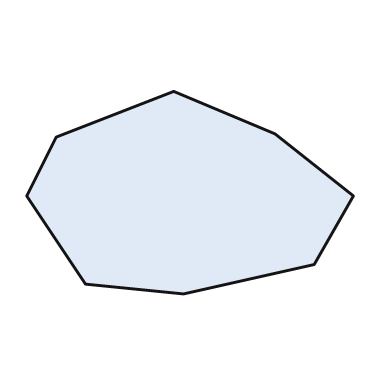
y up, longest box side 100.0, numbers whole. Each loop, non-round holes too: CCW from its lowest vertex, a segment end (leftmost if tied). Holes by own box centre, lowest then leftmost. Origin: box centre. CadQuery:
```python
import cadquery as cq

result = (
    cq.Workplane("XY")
    .moveTo(-2.0, -31.0)
    .lineTo(38.0, -22.0)
    .lineTo(50.0, -1.0)
    .lineTo(26.0, 18.0)
    .lineTo(-5.0, 31.0)
    .lineTo(-41.0, 17.0)
    .lineTo(-50.0, -1.0)
    .lineTo(-32.0, -28.0)
    .close()
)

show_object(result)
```